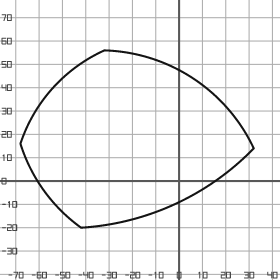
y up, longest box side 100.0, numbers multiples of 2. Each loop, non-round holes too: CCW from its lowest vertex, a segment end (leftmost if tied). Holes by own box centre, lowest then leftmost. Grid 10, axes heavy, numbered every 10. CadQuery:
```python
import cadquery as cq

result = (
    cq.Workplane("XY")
    .moveTo(-42.0, -20.0)
    .threePointArc((-2.0, -10.0), (32.0, 14.0))
    .threePointArc((6.0, 44.0), (-32.0, 56.0))
    .threePointArc((-54.0, 40.0), (-68.0, 16.0))
    .threePointArc((-58.0, -4.0), (-42.0, -20.0))
    .close()
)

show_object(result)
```